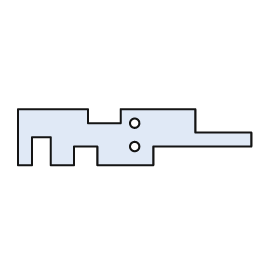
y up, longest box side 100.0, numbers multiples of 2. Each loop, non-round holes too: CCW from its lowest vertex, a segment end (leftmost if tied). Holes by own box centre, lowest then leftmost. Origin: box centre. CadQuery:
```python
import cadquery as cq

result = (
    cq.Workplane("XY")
    .moveTo(-50.0, -12.0)
    .lineTo(-44.0, -12.0)
    .lineTo(-44.0, 0.0)
    .lineTo(-36.0, 0.0)
    .lineTo(-36.0, -12.0)
    .lineTo(-26.0, -12.0)
    .lineTo(-26.0, -4.0)
    .lineTo(-16.0, -4.0)
    .lineTo(-16.0, -12.0)
    .lineTo(8.0, -12.0)
    .lineTo(8.0, -4.0)
    .lineTo(50.0, -4.0)
    .lineTo(50.0, 2.0)
    .lineTo(26.0, 2.0)
    .lineTo(26.0, 12.0)
    .lineTo(-6.0, 12.0)
    .lineTo(-6.0, 6.0)
    .lineTo(-20.0, 6.0)
    .lineTo(-20.0, 12.0)
    .lineTo(-50.0, 12.0)
    .close()
    .moveTo(0.0, -4.0)
    .circle(2.0)
    .moveTo(0.0, 6.0)
    .circle(2.0)
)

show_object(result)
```